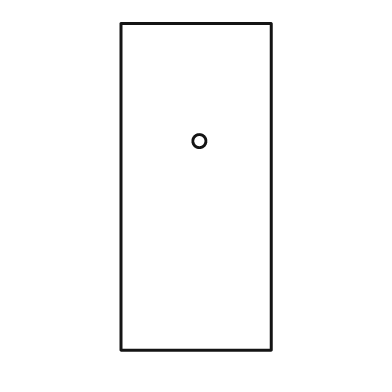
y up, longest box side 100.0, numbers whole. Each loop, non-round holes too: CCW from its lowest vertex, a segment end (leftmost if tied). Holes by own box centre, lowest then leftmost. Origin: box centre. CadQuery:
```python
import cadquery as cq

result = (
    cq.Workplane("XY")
    .moveTo(-23.0, -50.0)
    .lineTo(23.0, -50.0)
    .lineTo(23.0, 50.0)
    .lineTo(-23.0, 50.0)
    .close()
    .moveTo(1.0, 14.0)
    .circle(2.0)
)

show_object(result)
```